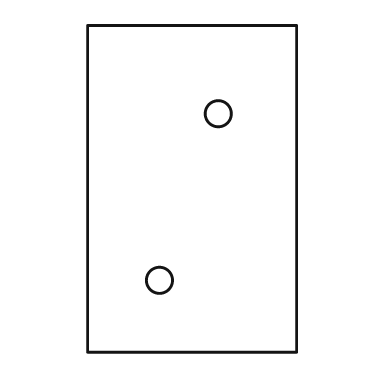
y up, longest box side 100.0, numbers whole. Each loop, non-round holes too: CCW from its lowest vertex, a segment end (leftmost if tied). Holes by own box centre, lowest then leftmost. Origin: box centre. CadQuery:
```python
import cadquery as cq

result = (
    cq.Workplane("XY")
    .moveTo(-32.0, -50.0)
    .lineTo(32.0, -50.0)
    .lineTo(32.0, 50.0)
    .lineTo(-32.0, 50.0)
    .close()
    .moveTo(-10.0, -28.0)
    .circle(4.0)
    .moveTo(8.0, 23.0)
    .circle(4.0)
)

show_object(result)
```